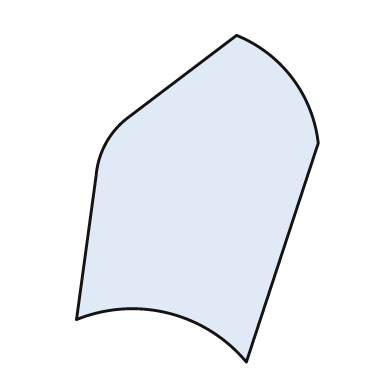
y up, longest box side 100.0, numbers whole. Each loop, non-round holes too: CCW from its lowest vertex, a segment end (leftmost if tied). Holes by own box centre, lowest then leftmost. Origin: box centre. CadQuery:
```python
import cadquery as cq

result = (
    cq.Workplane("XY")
    .moveTo(15.0, -50.0)
    .lineTo(37.0, 17.0)
    .threePointArc((29.0, 37.0), (12.0, 50.0))
    .lineTo(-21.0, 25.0)
    .threePointArc((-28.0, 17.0), (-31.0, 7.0))
    .lineTo(-37.0, -37.0)
    .threePointArc((-9.0, -35.0), (15.0, -50.0))
    .close()
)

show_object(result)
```